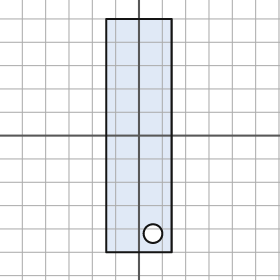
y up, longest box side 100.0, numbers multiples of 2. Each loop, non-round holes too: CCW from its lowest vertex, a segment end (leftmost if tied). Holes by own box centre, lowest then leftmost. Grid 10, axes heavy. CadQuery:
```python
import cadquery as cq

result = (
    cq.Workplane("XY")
    .moveTo(-14.0, -50.0)
    .lineTo(14.0, -50.0)
    .lineTo(14.0, 50.0)
    .lineTo(-14.0, 50.0)
    .close()
    .moveTo(6.0, -42.0)
    .circle(4.0)
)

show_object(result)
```